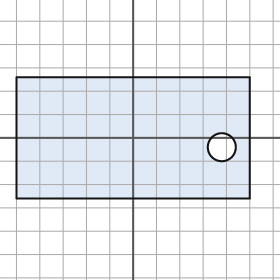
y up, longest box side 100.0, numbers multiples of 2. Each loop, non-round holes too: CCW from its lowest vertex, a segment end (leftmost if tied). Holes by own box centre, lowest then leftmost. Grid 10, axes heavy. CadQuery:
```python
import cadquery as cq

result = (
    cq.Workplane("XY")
    .moveTo(-50.0, -26.0)
    .lineTo(50.0, -26.0)
    .lineTo(50.0, 26.0)
    .lineTo(-50.0, 26.0)
    .close()
    .moveTo(38.0, -4.0)
    .circle(6.0)
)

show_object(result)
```